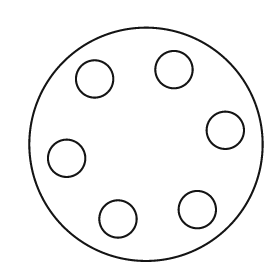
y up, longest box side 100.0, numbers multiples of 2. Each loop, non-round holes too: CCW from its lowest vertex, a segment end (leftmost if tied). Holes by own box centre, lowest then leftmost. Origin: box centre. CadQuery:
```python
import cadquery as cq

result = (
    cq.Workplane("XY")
    .moveTo(0.0, 0.0)
    .circle(50.0)
    .moveTo(-12.0, -32.0)
    .circle(8.0)
    .moveTo(22.0, -28.0)
    .circle(8.0)
    .moveTo(-34.0, -6.0)
    .circle(8.0)
    .moveTo(34.0, 6.0)
    .circle(8.0)
    .moveTo(-22.0, 28.0)
    .circle(8.0)
    .moveTo(12.0, 32.0)
    .circle(8.0)
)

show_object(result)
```